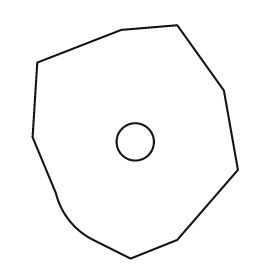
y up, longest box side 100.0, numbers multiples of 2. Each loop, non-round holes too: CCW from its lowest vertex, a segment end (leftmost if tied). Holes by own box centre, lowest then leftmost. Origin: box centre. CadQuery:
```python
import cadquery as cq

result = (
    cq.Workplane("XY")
    .moveTo(-2.0, -50.0)
    .lineTo(18.0, -42.0)
    .lineTo(44.0, -12.0)
    .lineTo(38.0, 22.0)
    .lineTo(18.0, 50.0)
    .lineTo(-6.0, 48.0)
    .lineTo(-42.0, 34.0)
    .lineTo(-44.0, 2.0)
    .lineTo(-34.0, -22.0)
    .threePointArc((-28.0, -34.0), (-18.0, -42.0))
    .close()
    .moveTo(0.0, 0.0)
    .circle(8.0)
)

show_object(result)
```